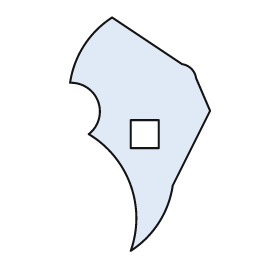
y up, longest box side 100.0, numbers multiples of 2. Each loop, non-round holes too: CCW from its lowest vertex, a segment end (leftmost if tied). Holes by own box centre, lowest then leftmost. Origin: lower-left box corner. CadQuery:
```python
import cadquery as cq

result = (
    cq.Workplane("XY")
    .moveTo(26.0, 0.0)
    .threePointArc((38.0, 12.0), (44.0, 28.0))
    .lineTo(60.0, 60.0)
    .lineTo(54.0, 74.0)
    .threePointArc((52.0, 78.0), (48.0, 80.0))
    .lineTo(18.0, 100.0)
    .threePointArc((6.0, 88.0), (0.0, 72.0))
    .threePointArc((12.0, 64.0), (8.0, 50.0))
    .threePointArc((26.0, 28.0), (26.0, 0.0))
    .close()
    .moveTo(26.0, 44.0)
    .lineTo(38.0, 44.0)
    .lineTo(38.0, 56.0)
    .lineTo(26.0, 56.0)
    .close()
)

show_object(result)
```